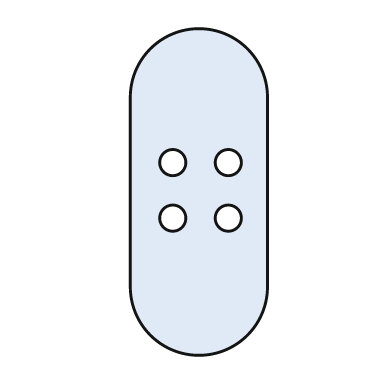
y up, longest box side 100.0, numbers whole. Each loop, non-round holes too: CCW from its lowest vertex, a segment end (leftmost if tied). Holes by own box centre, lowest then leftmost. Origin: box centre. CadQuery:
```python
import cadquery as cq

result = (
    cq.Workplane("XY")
    .moveTo(-21.0, -29.0)
    .threePointArc((0.0, -50.0), (21.0, -29.0))
    .lineTo(21.0, 29.0)
    .threePointArc((0.0, 50.0), (-21.0, 29.0))
    .close()
    .moveTo(-8.0, -8.0)
    .circle(4.0)
    .moveTo(9.0, -8.0)
    .circle(4.0)
    .moveTo(-8.0, 9.0)
    .circle(4.0)
    .moveTo(9.0, 9.0)
    .circle(4.0)
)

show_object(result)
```